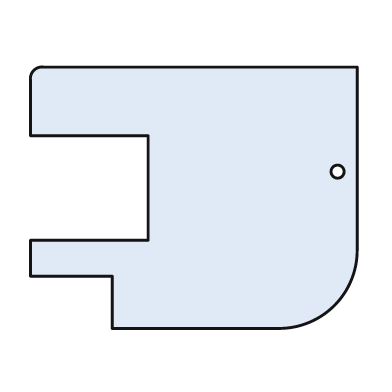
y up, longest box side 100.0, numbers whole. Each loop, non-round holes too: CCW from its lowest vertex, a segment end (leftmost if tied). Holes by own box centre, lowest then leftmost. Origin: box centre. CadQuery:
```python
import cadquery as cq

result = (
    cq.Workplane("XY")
    .moveTo(-25.0, -40.0)
    .lineTo(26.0, -40.0)
    .threePointArc((43.0, -33.0), (50.0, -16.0))
    .lineTo(50.0, 40.0)
    .lineTo(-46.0, 40.0)
    .threePointArc((-49.0, 39.0), (-50.0, 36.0))
    .lineTo(-50.0, 19.0)
    .lineTo(-14.0, 19.0)
    .lineTo(-14.0, -13.0)
    .lineTo(-50.0, -13.0)
    .lineTo(-50.0, -24.0)
    .lineTo(-25.0, -24.0)
    .close()
    .moveTo(44.0, 8.0)
    .circle(2.0)
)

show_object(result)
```